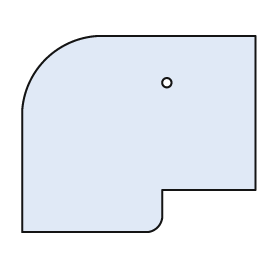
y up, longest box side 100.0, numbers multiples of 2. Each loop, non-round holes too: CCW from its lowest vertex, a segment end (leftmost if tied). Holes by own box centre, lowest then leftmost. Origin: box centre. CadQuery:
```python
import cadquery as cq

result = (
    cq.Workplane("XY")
    .moveTo(-50.0, -42.0)
    .lineTo(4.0, -42.0)
    .threePointArc((8.0, -40.0), (10.0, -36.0))
    .lineTo(10.0, -24.0)
    .lineTo(50.0, -24.0)
    .lineTo(50.0, 42.0)
    .lineTo(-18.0, 42.0)
    .threePointArc((-40.0, 32.0), (-50.0, 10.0))
    .close()
    .moveTo(12.0, 22.0)
    .circle(2.0)
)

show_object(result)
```